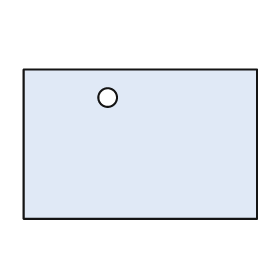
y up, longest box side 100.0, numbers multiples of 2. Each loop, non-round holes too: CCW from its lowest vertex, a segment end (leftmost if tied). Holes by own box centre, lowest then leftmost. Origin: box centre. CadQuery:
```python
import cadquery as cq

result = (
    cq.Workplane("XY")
    .moveTo(-50.0, -32.0)
    .lineTo(50.0, -32.0)
    .lineTo(50.0, 32.0)
    .lineTo(-50.0, 32.0)
    .close()
    .moveTo(-14.0, 20.0)
    .circle(4.0)
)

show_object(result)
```